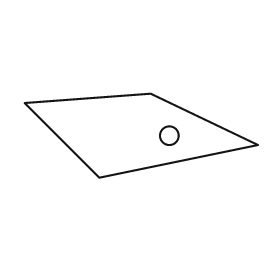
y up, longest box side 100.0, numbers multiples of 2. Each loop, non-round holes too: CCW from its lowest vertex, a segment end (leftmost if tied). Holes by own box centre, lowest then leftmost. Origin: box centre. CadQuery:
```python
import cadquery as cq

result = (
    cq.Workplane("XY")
    .moveTo(-18.0, -18.0)
    .lineTo(50.0, -4.0)
    .lineTo(4.0, 18.0)
    .lineTo(-50.0, 14.0)
    .close()
    .moveTo(12.0, 0.0)
    .circle(4.0)
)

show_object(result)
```